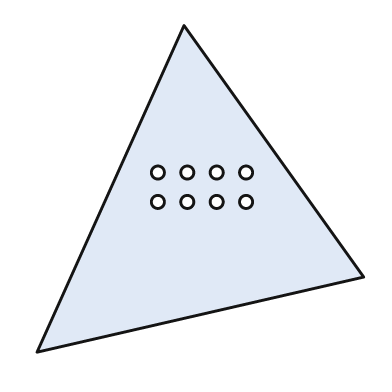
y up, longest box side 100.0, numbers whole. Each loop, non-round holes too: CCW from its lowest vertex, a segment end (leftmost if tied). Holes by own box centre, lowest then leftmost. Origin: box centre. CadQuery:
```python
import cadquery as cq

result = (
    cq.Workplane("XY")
    .moveTo(-50.0, -50.0)
    .lineTo(50.0, -27.0)
    .lineTo(-5.0, 50.0)
    .close()
    .moveTo(-13.0, -4.0)
    .circle(2.0)
    .moveTo(-4.0, -4.0)
    .circle(2.0)
    .moveTo(5.0, -4.0)
    .circle(2.0)
    .moveTo(14.0, -4.0)
    .circle(2.0)
    .moveTo(-13.0, 5.0)
    .circle(2.0)
    .moveTo(-4.0, 5.0)
    .circle(2.0)
    .moveTo(5.0, 5.0)
    .circle(2.0)
    .moveTo(14.0, 5.0)
    .circle(2.0)
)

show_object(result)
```